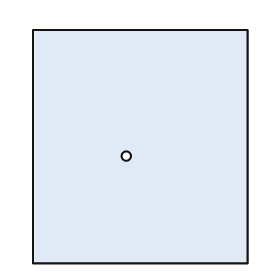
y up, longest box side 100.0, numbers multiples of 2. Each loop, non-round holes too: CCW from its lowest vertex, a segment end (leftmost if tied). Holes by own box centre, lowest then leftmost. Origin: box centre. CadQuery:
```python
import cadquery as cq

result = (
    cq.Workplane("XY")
    .moveTo(-46.0, -50.0)
    .lineTo(46.0, -50.0)
    .lineTo(46.0, 50.0)
    .lineTo(-46.0, 50.0)
    .close()
    .moveTo(-6.0, -4.0)
    .circle(2.0)
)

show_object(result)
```